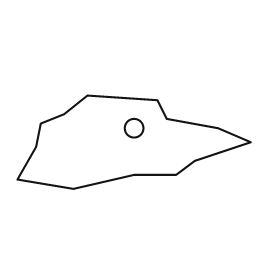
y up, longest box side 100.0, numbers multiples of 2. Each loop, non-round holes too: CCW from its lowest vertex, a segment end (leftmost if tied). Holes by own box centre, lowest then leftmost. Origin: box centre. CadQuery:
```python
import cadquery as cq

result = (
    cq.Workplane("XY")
    .moveTo(-26.0, -20.0)
    .lineTo(0.0, -14.0)
    .lineTo(18.0, -14.0)
    .lineTo(26.0, -8.0)
    .lineTo(50.0, 0.0)
    .lineTo(36.0, 6.0)
    .lineTo(14.0, 10.0)
    .lineTo(10.0, 18.0)
    .lineTo(-20.0, 20.0)
    .lineTo(-30.0, 12.0)
    .lineTo(-40.0, 8.0)
    .lineTo(-42.0, -2.0)
    .lineTo(-50.0, -16.0)
    .close()
    .moveTo(0.0, 6.0)
    .circle(4.0)
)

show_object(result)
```